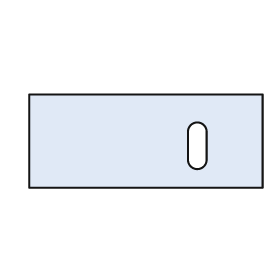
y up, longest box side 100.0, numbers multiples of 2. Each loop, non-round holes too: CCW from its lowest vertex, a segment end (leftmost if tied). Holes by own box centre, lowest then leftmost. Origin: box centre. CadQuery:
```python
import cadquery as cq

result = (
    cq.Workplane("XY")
    .moveTo(-50.0, -20.0)
    .lineTo(50.0, -20.0)
    .lineTo(50.0, 20.0)
    .lineTo(-50.0, 20.0)
    .close()
    .moveTo(18.0, -8.0)
    .threePointArc((22.0, -12.0), (26.0, -8.0))
    .lineTo(26.0, 4.0)
    .threePointArc((22.0, 8.0), (18.0, 4.0))
    .close()
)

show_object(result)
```